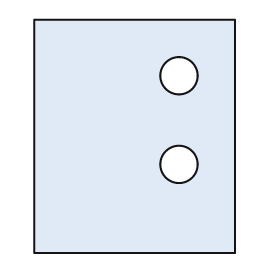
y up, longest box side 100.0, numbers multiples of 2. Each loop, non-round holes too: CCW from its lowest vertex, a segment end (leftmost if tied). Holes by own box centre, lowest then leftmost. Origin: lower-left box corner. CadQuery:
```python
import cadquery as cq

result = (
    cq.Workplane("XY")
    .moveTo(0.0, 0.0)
    .lineTo(86.0, 0.0)
    .lineTo(86.0, 100.0)
    .lineTo(0.0, 100.0)
    .close()
    .moveTo(62.0, 38.0)
    .circle(8.0)
    .moveTo(62.0, 76.0)
    .circle(8.0)
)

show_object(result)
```